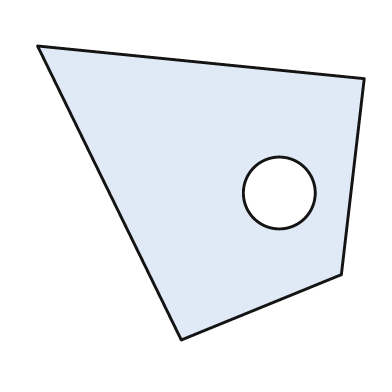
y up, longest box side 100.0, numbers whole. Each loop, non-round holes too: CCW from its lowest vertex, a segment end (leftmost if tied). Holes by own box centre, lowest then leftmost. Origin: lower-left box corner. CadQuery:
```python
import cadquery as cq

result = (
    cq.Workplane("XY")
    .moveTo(44.0, 0.0)
    .lineTo(93.0, 20.0)
    .lineTo(100.0, 80.0)
    .lineTo(0.0, 90.0)
    .close()
    .moveTo(74.0, 45.0)
    .circle(11.0)
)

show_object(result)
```